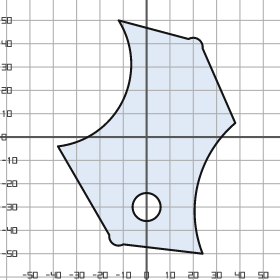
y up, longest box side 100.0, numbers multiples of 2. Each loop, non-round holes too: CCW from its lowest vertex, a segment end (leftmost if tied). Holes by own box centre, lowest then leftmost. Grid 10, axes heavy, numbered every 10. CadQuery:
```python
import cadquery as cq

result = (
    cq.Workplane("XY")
    .moveTo(24.0, -50.0)
    .threePointArc((22.0, -20.0), (38.0, 6.0))
    .lineTo(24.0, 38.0)
    .threePointArc((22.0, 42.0), (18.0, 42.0))
    .lineTo(-12.0, 50.0)
    .threePointArc((-10.0, 16.0), (-38.0, -4.0))
    .lineTo(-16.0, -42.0)
    .threePointArc((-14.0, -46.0), (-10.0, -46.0))
    .close()
    .moveTo(0.0, -30.0)
    .circle(6.0)
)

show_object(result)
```